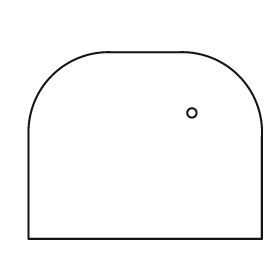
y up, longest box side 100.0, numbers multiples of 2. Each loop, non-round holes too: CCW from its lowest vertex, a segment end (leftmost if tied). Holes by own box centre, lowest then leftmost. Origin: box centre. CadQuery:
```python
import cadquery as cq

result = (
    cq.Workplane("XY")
    .moveTo(-50.0, -40.0)
    .lineTo(50.0, -40.0)
    .lineTo(50.0, 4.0)
    .threePointArc((40.0, 30.0), (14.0, 40.0))
    .lineTo(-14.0, 40.0)
    .threePointArc((-40.0, 30.0), (-50.0, 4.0))
    .close()
    .moveTo(20.0, 14.0)
    .circle(2.0)
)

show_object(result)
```